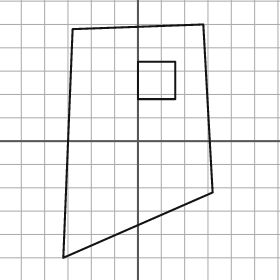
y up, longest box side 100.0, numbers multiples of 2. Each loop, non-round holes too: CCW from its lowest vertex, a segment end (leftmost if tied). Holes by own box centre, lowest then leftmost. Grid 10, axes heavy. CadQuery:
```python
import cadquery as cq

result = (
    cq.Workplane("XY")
    .moveTo(-32.0, -50.0)
    .lineTo(32.0, -22.0)
    .lineTo(28.0, 50.0)
    .lineTo(-28.0, 48.0)
    .close()
    .moveTo(0.0, 18.0)
    .lineTo(16.0, 18.0)
    .lineTo(16.0, 34.0)
    .lineTo(0.0, 34.0)
    .close()
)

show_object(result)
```